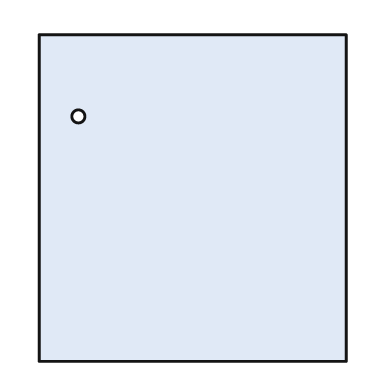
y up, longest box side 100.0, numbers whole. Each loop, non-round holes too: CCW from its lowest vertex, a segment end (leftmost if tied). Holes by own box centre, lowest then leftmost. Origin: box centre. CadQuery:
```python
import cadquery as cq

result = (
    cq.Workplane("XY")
    .moveTo(-47.0, -50.0)
    .lineTo(47.0, -50.0)
    .lineTo(47.0, 50.0)
    .lineTo(-47.0, 50.0)
    .close()
    .moveTo(-35.0, 25.0)
    .circle(2.0)
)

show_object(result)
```